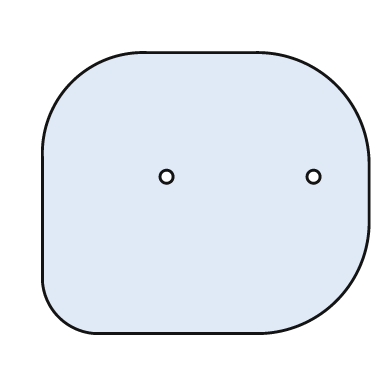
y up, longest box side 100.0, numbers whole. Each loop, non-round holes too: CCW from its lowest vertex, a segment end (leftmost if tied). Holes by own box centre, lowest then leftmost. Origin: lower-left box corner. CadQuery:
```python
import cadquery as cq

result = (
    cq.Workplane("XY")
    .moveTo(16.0, 0.0)
    .lineTo(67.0, 0.0)
    .threePointArc((90.0, 10.0), (100.0, 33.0))
    .lineTo(100.0, 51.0)
    .threePointArc((90.0, 76.0), (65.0, 86.0))
    .lineTo(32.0, 86.0)
    .threePointArc((9.0, 77.0), (0.0, 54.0))
    .lineTo(0.0, 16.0)
    .threePointArc((5.0, 5.0), (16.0, 0.0))
    .close()
    .moveTo(38.0, 48.0)
    .circle(2.0)
    .moveTo(83.0, 48.0)
    .circle(2.0)
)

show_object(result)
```